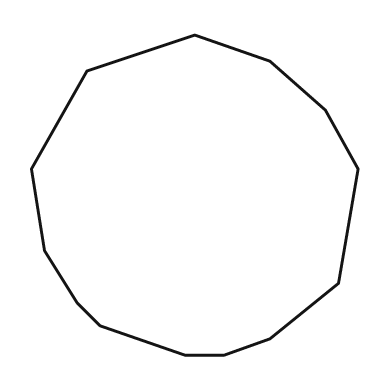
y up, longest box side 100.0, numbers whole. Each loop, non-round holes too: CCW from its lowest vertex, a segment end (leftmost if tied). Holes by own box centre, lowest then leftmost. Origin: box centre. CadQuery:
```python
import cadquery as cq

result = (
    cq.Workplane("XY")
    .moveTo(-3.0, -49.0)
    .lineTo(9.0, -49.0)
    .lineTo(23.0, -44.0)
    .lineTo(44.0, -27.0)
    .lineTo(50.0, 8.0)
    .lineTo(40.0, 26.0)
    .lineTo(23.0, 41.0)
    .lineTo(0.0, 49.0)
    .lineTo(-33.0, 38.0)
    .lineTo(-50.0, 8.0)
    .lineTo(-46.0, -17.0)
    .lineTo(-36.0, -33.0)
    .lineTo(-29.0, -40.0)
    .close()
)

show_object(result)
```